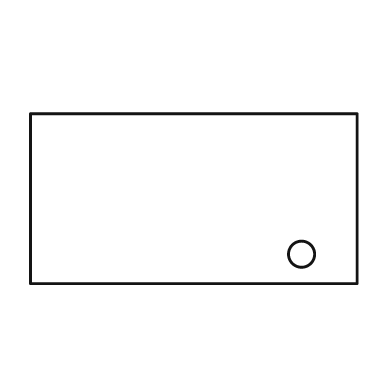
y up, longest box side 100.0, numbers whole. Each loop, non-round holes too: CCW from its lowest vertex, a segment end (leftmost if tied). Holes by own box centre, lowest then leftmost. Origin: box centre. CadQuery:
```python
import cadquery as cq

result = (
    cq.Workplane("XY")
    .moveTo(-50.0, -26.0)
    .lineTo(50.0, -26.0)
    .lineTo(50.0, 26.0)
    .lineTo(-50.0, 26.0)
    .close()
    .moveTo(33.0, -17.0)
    .circle(4.0)
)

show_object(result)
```